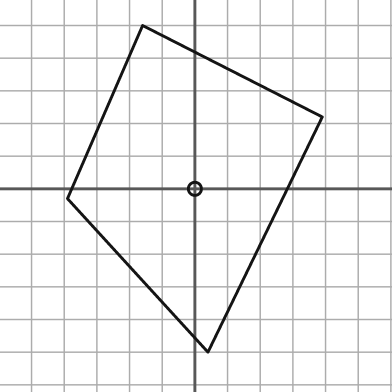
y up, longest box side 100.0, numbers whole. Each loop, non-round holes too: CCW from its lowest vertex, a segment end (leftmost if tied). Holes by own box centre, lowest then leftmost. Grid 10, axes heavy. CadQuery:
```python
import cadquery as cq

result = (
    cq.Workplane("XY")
    .moveTo(4.0, -50.0)
    .lineTo(39.0, 22.0)
    .lineTo(-16.0, 50.0)
    .lineTo(-39.0, -3.0)
    .close()
    .moveTo(0.0, 0.0)
    .circle(2.0)
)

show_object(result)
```